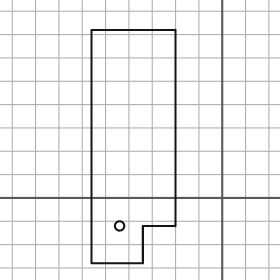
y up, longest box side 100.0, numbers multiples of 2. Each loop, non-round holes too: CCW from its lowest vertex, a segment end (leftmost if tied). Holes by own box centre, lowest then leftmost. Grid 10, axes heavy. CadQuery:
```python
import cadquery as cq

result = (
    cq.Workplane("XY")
    .moveTo(-56.0, -28.0)
    .lineTo(-34.0, -28.0)
    .lineTo(-34.0, -12.0)
    .lineTo(-20.0, -12.0)
    .lineTo(-20.0, 72.0)
    .lineTo(-56.0, 72.0)
    .close()
    .moveTo(-44.0, -12.0)
    .circle(2.0)
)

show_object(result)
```